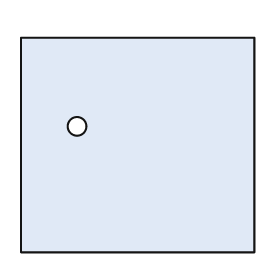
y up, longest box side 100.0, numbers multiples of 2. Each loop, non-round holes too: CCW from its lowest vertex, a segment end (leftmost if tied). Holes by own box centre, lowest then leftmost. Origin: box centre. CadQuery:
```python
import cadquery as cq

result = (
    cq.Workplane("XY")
    .moveTo(-50.0, -46.0)
    .lineTo(50.0, -46.0)
    .lineTo(50.0, 46.0)
    .lineTo(-50.0, 46.0)
    .close()
    .moveTo(-26.0, 8.0)
    .circle(4.0)
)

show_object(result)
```